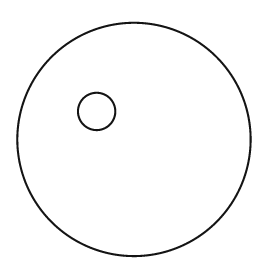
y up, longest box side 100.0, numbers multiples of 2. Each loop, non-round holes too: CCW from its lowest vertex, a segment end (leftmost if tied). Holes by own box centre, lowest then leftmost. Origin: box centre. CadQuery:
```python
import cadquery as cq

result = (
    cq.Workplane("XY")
    .moveTo(0.0, 0.0)
    .circle(50.0)
    .moveTo(-16.0, 12.0)
    .circle(8.0)
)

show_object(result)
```